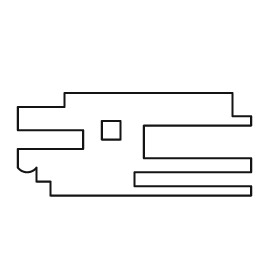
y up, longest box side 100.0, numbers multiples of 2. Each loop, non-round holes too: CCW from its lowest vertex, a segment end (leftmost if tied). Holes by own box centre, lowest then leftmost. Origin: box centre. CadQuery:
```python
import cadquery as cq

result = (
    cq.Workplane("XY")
    .moveTo(-36.0, -22.0)
    .lineTo(50.0, -22.0)
    .lineTo(50.0, -18.0)
    .lineTo(0.0, -18.0)
    .lineTo(0.0, -12.0)
    .lineTo(50.0, -12.0)
    .lineTo(50.0, -6.0)
    .lineTo(4.0, -6.0)
    .lineTo(4.0, 8.0)
    .lineTo(50.0, 8.0)
    .lineTo(50.0, 12.0)
    .lineTo(42.0, 12.0)
    .lineTo(42.0, 22.0)
    .lineTo(-30.0, 22.0)
    .lineTo(-30.0, 16.0)
    .lineTo(-50.0, 16.0)
    .lineTo(-50.0, 6.0)
    .lineTo(-22.0, 6.0)
    .lineTo(-22.0, -2.0)
    .lineTo(-50.0, -2.0)
    .lineTo(-50.0, -10.0)
    .threePointArc((-46.0, -12.0), (-42.0, -10.0))
    .lineTo(-42.0, -16.0)
    .lineTo(-36.0, -16.0)
    .close()
    .moveTo(-14.0, 2.0)
    .lineTo(-6.0, 2.0)
    .lineTo(-6.0, 10.0)
    .lineTo(-14.0, 10.0)
    .close()
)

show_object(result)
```